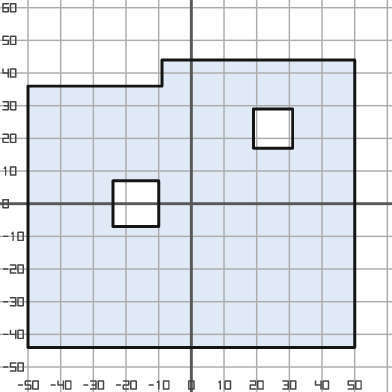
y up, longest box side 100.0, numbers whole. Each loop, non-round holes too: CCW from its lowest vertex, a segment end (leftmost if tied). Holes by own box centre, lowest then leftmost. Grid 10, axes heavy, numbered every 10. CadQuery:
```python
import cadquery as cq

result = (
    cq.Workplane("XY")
    .moveTo(-50.0, -44.0)
    .lineTo(50.0, -44.0)
    .lineTo(50.0, 44.0)
    .lineTo(-9.0, 44.0)
    .lineTo(-9.0, 36.0)
    .lineTo(-50.0, 36.0)
    .close()
    .moveTo(-24.0, -7.0)
    .lineTo(-10.0, -7.0)
    .lineTo(-10.0, 7.0)
    .lineTo(-24.0, 7.0)
    .close()
    .moveTo(19.0, 17.0)
    .lineTo(31.0, 17.0)
    .lineTo(31.0, 29.0)
    .lineTo(19.0, 29.0)
    .close()
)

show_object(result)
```